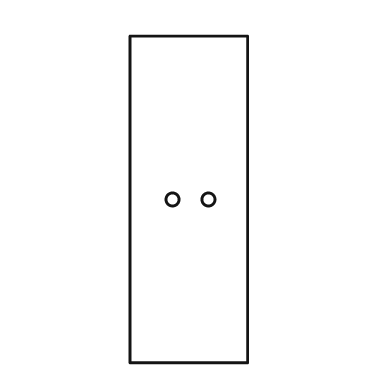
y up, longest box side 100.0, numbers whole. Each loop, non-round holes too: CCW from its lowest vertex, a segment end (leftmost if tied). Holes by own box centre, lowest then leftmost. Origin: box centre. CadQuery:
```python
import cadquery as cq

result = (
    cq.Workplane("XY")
    .moveTo(-18.0, -50.0)
    .lineTo(18.0, -50.0)
    .lineTo(18.0, 50.0)
    .lineTo(-18.0, 50.0)
    .close()
    .moveTo(-5.0, 0.0)
    .circle(2.0)
    .moveTo(6.0, 0.0)
    .circle(2.0)
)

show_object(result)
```